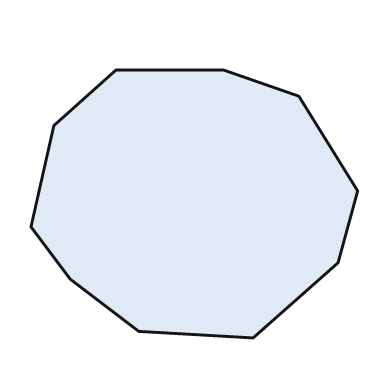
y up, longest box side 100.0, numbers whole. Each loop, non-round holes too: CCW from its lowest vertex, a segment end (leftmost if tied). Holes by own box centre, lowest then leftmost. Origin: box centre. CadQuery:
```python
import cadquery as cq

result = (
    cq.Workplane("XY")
    .moveTo(18.0, -41.0)
    .lineTo(44.0, -18.0)
    .lineTo(50.0, 4.0)
    .lineTo(32.0, 33.0)
    .lineTo(9.0, 41.0)
    .lineTo(-24.0, 41.0)
    .lineTo(-43.0, 24.0)
    .lineTo(-50.0, -7.0)
    .lineTo(-38.0, -23.0)
    .lineTo(-17.0, -39.0)
    .close()
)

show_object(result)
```